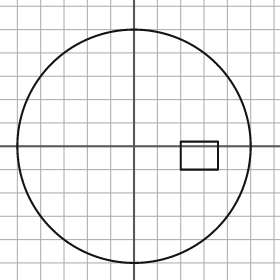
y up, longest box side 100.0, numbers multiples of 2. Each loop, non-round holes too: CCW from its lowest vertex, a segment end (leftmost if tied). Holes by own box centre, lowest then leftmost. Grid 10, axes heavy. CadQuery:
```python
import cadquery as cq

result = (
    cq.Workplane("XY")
    .moveTo(0.0, 0.0)
    .circle(50.0)
    .moveTo(20.0, -10.0)
    .lineTo(36.0, -10.0)
    .lineTo(36.0, 2.0)
    .lineTo(20.0, 2.0)
    .close()
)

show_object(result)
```